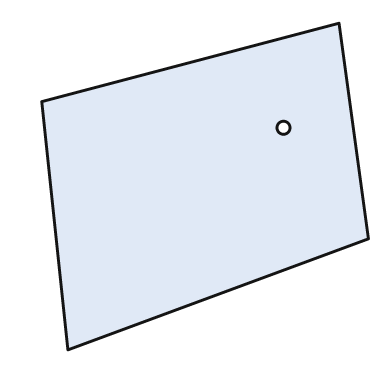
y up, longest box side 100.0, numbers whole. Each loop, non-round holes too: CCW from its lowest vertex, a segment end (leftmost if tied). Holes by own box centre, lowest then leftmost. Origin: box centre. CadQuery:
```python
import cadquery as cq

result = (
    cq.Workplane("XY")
    .moveTo(-42.0, -50.0)
    .lineTo(50.0, -16.0)
    .lineTo(41.0, 50.0)
    .lineTo(-50.0, 26.0)
    .close()
    .moveTo(24.0, 18.0)
    .circle(2.0)
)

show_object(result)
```